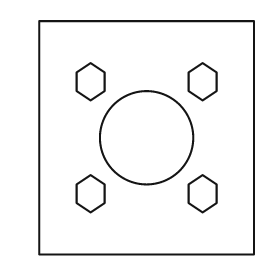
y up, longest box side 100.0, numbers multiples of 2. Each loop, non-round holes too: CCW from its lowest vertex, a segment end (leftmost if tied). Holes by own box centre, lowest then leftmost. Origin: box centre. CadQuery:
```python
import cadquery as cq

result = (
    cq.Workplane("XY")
    .moveTo(-46.0, -50.0)
    .lineTo(46.0, -50.0)
    .lineTo(46.0, 50.0)
    .lineTo(-46.0, 50.0)
    .close()
    .moveTo(-24.0, -32.0)
    .lineTo(-18.0, -28.0)
    .lineTo(-18.0, -20.0)
    .lineTo(-24.0, -16.0)
    .lineTo(-30.0, -20.0)
    .lineTo(-30.0, -28.0)
    .close()
    .moveTo(24.0, -32.0)
    .lineTo(30.0, -28.0)
    .lineTo(30.0, -20.0)
    .lineTo(24.0, -16.0)
    .lineTo(18.0, -20.0)
    .lineTo(18.0, -28.0)
    .close()
    .moveTo(0.0, 0.0)
    .circle(20.0)
    .moveTo(-24.0, 16.0)
    .lineTo(-18.0, 20.0)
    .lineTo(-18.0, 28.0)
    .lineTo(-24.0, 32.0)
    .lineTo(-30.0, 28.0)
    .lineTo(-30.0, 20.0)
    .close()
    .moveTo(24.0, 16.0)
    .lineTo(30.0, 20.0)
    .lineTo(30.0, 28.0)
    .lineTo(24.0, 32.0)
    .lineTo(18.0, 28.0)
    .lineTo(18.0, 20.0)
    .close()
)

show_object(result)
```